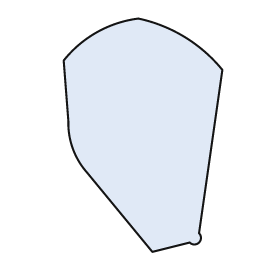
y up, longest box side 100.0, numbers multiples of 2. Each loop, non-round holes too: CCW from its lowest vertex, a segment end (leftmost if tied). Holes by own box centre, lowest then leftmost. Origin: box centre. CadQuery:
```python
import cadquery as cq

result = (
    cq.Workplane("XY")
    .moveTo(4.0, -50.0)
    .lineTo(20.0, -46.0)
    .threePointArc((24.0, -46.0), (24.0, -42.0))
    .lineTo(34.0, 28.0)
    .threePointArc((18.0, 42.0), (-2.0, 50.0))
    .threePointArc((-20.0, 44.0), (-34.0, 32.0))
    .lineTo(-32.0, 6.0)
    .threePointArc((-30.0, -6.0), (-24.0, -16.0))
    .close()
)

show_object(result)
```